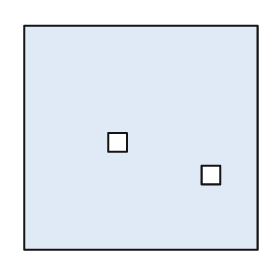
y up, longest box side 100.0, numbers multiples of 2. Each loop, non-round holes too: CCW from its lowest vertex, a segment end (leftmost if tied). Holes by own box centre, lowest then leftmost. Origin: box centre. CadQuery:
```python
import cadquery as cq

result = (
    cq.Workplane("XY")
    .moveTo(-50.0, -48.0)
    .lineTo(50.0, -48.0)
    .lineTo(50.0, 48.0)
    .lineTo(-50.0, 48.0)
    .close()
    .moveTo(26.0, -20.0)
    .lineTo(34.0, -20.0)
    .lineTo(34.0, -12.0)
    .lineTo(26.0, -12.0)
    .close()
    .moveTo(-14.0, -6.0)
    .lineTo(-6.0, -6.0)
    .lineTo(-6.0, 2.0)
    .lineTo(-14.0, 2.0)
    .close()
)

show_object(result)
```